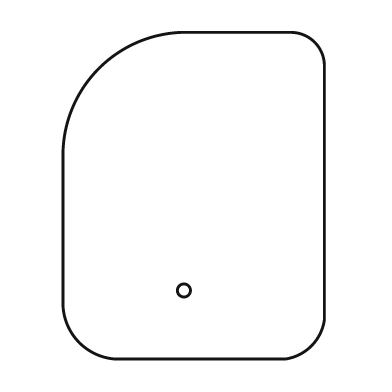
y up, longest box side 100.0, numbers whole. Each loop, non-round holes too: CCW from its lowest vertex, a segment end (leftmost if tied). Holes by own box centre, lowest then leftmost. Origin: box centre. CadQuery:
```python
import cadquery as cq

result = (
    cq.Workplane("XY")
    .moveTo(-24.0, -50.0)
    .lineTo(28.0, -50.0)
    .threePointArc((36.0, -46.0), (40.0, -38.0))
    .lineTo(40.0, 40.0)
    .threePointArc((37.0, 47.0), (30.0, 50.0))
    .lineTo(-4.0, 50.0)
    .threePointArc((-29.0, 39.0), (-40.0, 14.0))
    .lineTo(-40.0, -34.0)
    .threePointArc((-35.0, -45.0), (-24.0, -50.0))
    .close()
    .moveTo(-3.0, -29.0)
    .circle(2.0)
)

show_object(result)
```